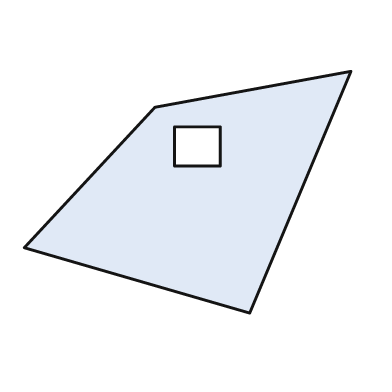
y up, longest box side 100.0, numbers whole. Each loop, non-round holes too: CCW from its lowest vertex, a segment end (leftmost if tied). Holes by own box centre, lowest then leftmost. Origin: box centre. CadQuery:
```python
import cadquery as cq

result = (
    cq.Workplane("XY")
    .moveTo(19.0, -37.0)
    .lineTo(50.0, 37.0)
    .lineTo(-10.0, 26.0)
    .lineTo(-50.0, -17.0)
    .close()
    .moveTo(-4.0, 8.0)
    .lineTo(10.0, 8.0)
    .lineTo(10.0, 20.0)
    .lineTo(-4.0, 20.0)
    .close()
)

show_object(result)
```